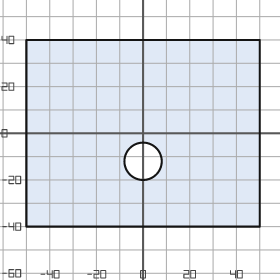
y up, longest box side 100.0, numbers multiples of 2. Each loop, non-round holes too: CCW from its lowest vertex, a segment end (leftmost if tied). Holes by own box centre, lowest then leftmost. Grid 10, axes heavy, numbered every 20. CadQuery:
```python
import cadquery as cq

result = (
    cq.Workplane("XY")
    .moveTo(-50.0, -40.0)
    .lineTo(50.0, -40.0)
    .lineTo(50.0, 40.0)
    .lineTo(-50.0, 40.0)
    .close()
    .moveTo(0.0, -12.0)
    .circle(8.0)
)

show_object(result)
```